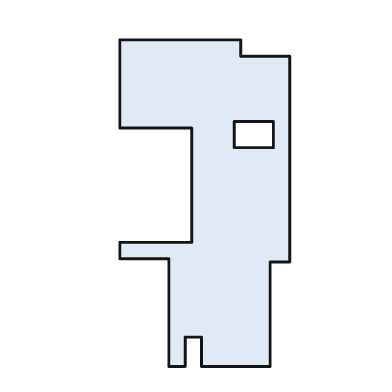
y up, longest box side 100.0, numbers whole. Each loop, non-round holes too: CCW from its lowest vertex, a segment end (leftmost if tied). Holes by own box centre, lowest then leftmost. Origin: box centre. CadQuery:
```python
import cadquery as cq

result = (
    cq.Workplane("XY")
    .moveTo(-11.0, -50.0)
    .lineTo(-6.0, -50.0)
    .lineTo(-6.0, -41.0)
    .lineTo(-1.0, -41.0)
    .lineTo(-1.0, -50.0)
    .lineTo(20.0, -50.0)
    .lineTo(20.0, -18.0)
    .lineTo(26.0, -18.0)
    .lineTo(26.0, 45.0)
    .lineTo(11.0, 45.0)
    .lineTo(11.0, 50.0)
    .lineTo(-26.0, 50.0)
    .lineTo(-26.0, 23.0)
    .lineTo(-4.0, 23.0)
    .lineTo(-4.0, -12.0)
    .lineTo(-26.0, -12.0)
    .lineTo(-26.0, -17.0)
    .lineTo(-11.0, -17.0)
    .close()
    .moveTo(9.0, 17.0)
    .lineTo(21.0, 17.0)
    .lineTo(21.0, 25.0)
    .lineTo(9.0, 25.0)
    .close()
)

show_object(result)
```